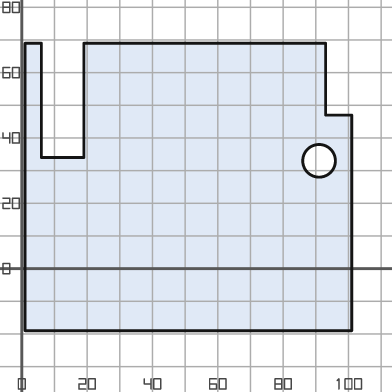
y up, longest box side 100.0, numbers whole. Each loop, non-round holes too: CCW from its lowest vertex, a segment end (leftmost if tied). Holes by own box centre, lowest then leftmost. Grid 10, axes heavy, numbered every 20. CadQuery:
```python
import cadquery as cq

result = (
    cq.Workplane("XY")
    .moveTo(1.0, -19.0)
    .lineTo(101.0, -19.0)
    .lineTo(101.0, 47.0)
    .lineTo(93.0, 47.0)
    .lineTo(93.0, 69.0)
    .lineTo(19.0, 69.0)
    .lineTo(19.0, 34.0)
    .lineTo(6.0, 34.0)
    .lineTo(6.0, 69.0)
    .lineTo(1.0, 69.0)
    .close()
    .moveTo(91.0, 33.0)
    .circle(5.0)
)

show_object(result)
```